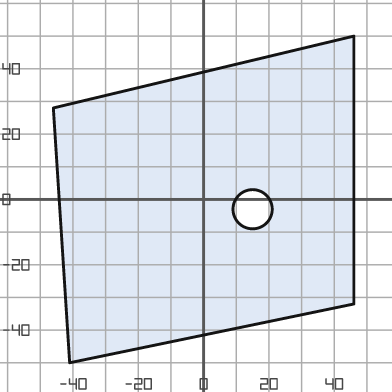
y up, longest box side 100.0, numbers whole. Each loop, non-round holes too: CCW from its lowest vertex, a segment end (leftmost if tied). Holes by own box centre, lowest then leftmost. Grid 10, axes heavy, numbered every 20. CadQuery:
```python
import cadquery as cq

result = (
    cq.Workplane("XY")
    .moveTo(-41.0, -50.0)
    .lineTo(46.0, -32.0)
    .lineTo(46.0, 50.0)
    .lineTo(-46.0, 28.0)
    .close()
    .moveTo(15.0, -3.0)
    .circle(6.0)
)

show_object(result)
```